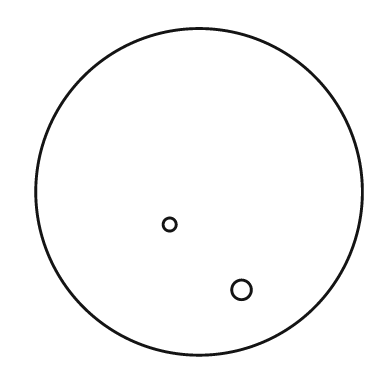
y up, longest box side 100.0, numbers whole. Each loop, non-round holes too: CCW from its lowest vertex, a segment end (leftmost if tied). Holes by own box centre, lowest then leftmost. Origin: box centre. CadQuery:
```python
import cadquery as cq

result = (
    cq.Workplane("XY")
    .moveTo(0.0, 0.0)
    .circle(50.0)
    .moveTo(13.0, -30.0)
    .circle(3.0)
    .moveTo(-9.0, -10.0)
    .circle(2.0)
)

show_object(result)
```